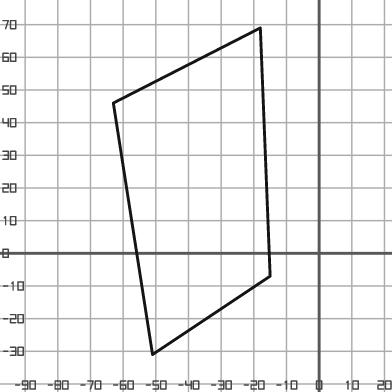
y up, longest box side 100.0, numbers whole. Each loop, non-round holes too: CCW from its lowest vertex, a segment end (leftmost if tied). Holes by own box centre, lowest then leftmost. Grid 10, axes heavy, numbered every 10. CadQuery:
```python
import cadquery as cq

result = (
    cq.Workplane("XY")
    .moveTo(-51.0, -31.0)
    .lineTo(-15.0, -7.0)
    .lineTo(-18.0, 69.0)
    .lineTo(-63.0, 46.0)
    .close()
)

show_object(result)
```